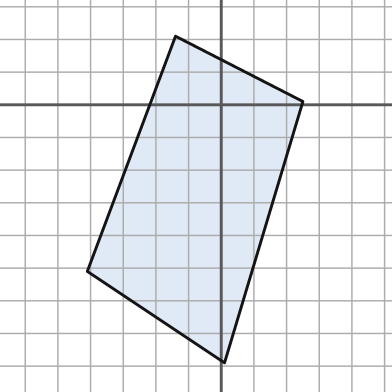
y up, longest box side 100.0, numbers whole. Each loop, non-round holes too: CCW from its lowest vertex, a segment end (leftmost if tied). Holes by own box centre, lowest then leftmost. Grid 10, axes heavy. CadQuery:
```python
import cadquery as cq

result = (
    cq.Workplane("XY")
    .moveTo(1.0, -79.0)
    .lineTo(25.0, 1.0)
    .lineTo(-14.0, 21.0)
    .lineTo(-41.0, -51.0)
    .close()
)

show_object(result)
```